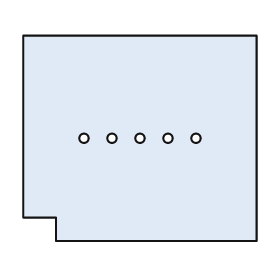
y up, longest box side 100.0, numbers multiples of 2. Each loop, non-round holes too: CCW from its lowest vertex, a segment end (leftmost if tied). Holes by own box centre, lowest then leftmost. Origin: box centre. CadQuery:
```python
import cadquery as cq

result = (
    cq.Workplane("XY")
    .moveTo(-36.0, -44.0)
    .lineTo(50.0, -44.0)
    .lineTo(50.0, 44.0)
    .lineTo(-50.0, 44.0)
    .lineTo(-50.0, -34.0)
    .lineTo(-36.0, -34.0)
    .close()
    .moveTo(-24.0, 0.0)
    .circle(2.0)
    .moveTo(-12.0, 0.0)
    .circle(2.0)
    .moveTo(0.0, 0.0)
    .circle(2.0)
    .moveTo(12.0, 0.0)
    .circle(2.0)
    .moveTo(24.0, 0.0)
    .circle(2.0)
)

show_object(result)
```